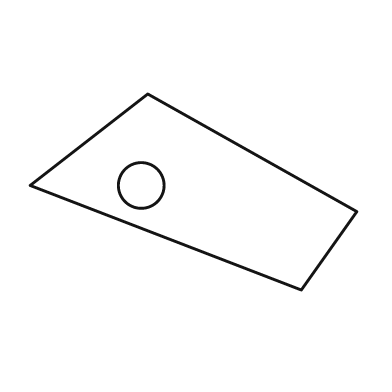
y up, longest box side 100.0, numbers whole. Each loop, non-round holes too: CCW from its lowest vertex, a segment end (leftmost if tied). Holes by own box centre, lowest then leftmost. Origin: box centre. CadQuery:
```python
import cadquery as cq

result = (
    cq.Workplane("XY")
    .moveTo(33.0, -30.0)
    .lineTo(50.0, -6.0)
    .lineTo(-14.0, 30.0)
    .lineTo(-50.0, 2.0)
    .close()
    .moveTo(-16.0, 2.0)
    .circle(7.0)
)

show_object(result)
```